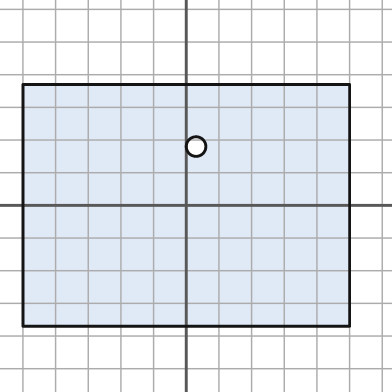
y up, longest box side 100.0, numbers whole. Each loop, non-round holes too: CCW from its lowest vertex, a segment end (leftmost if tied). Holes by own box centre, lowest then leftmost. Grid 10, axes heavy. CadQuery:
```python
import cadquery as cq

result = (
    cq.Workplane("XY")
    .moveTo(-50.0, -37.0)
    .lineTo(50.0, -37.0)
    .lineTo(50.0, 37.0)
    .lineTo(-50.0, 37.0)
    .close()
    .moveTo(3.0, 18.0)
    .circle(3.0)
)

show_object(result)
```